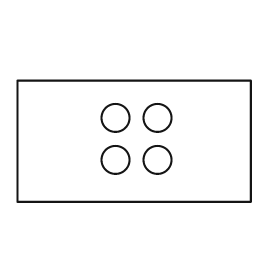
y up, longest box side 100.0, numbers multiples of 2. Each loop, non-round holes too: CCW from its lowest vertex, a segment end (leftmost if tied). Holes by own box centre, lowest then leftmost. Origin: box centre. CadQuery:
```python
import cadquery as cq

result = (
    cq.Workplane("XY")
    .moveTo(-50.0, -26.0)
    .lineTo(50.0, -26.0)
    .lineTo(50.0, 26.0)
    .lineTo(-50.0, 26.0)
    .close()
    .moveTo(-8.0, -8.0)
    .circle(6.0)
    .moveTo(10.0, -8.0)
    .circle(6.0)
    .moveTo(-8.0, 10.0)
    .circle(6.0)
    .moveTo(10.0, 10.0)
    .circle(6.0)
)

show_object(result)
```